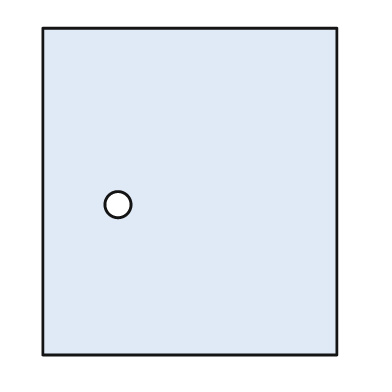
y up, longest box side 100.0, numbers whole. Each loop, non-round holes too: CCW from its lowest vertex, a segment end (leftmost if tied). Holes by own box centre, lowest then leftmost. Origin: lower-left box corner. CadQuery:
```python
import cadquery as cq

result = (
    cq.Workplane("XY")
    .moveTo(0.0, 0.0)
    .lineTo(90.0, 0.0)
    .lineTo(90.0, 100.0)
    .lineTo(0.0, 100.0)
    .close()
    .moveTo(23.0, 46.0)
    .circle(4.0)
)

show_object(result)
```